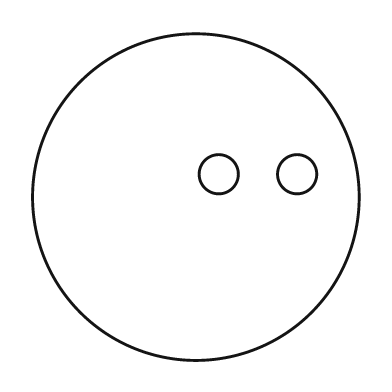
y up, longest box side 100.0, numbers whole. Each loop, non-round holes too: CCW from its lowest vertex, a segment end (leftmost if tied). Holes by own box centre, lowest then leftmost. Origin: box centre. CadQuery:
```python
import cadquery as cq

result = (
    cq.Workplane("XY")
    .moveTo(0.0, 0.0)
    .circle(50.0)
    .moveTo(7.0, 7.0)
    .circle(6.0)
    .moveTo(31.0, 7.0)
    .circle(6.0)
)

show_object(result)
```